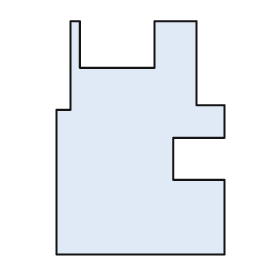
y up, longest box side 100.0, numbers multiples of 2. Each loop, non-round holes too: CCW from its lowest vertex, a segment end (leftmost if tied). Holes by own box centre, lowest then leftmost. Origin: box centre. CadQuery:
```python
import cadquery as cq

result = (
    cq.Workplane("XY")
    .moveTo(-36.0, -50.0)
    .lineTo(36.0, -50.0)
    .lineTo(36.0, -18.0)
    .lineTo(14.0, -18.0)
    .lineTo(14.0, 0.0)
    .lineTo(36.0, 0.0)
    .lineTo(36.0, 14.0)
    .lineTo(24.0, 14.0)
    .lineTo(24.0, 50.0)
    .lineTo(6.0, 50.0)
    .lineTo(6.0, 30.0)
    .lineTo(-26.0, 30.0)
    .lineTo(-26.0, 50.0)
    .lineTo(-30.0, 50.0)
    .lineTo(-30.0, 12.0)
    .lineTo(-36.0, 12.0)
    .close()
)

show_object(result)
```